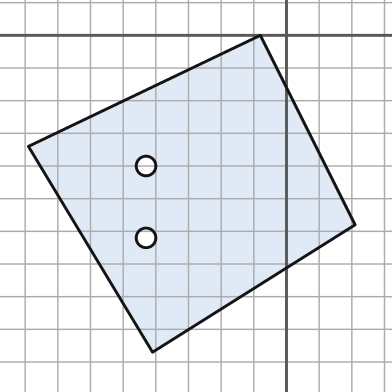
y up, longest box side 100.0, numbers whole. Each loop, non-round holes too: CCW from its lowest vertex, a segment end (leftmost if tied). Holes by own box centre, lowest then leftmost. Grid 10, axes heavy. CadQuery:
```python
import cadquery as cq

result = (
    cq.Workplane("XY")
    .moveTo(-41.0, -97.0)
    .lineTo(21.0, -58.0)
    .lineTo(-8.0, 0.0)
    .lineTo(-79.0, -34.0)
    .close()
    .moveTo(-43.0, -62.0)
    .circle(3.0)
    .moveTo(-43.0, -40.0)
    .circle(3.0)
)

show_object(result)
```